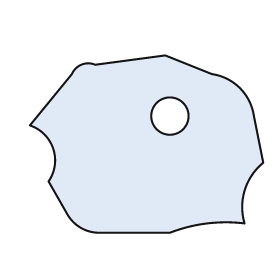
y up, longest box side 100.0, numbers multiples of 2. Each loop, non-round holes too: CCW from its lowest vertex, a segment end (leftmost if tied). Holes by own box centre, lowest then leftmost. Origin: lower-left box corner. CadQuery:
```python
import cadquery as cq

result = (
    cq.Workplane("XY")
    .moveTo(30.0, 0.0)
    .lineTo(60.0, 0.0)
    .threePointArc((76.0, 4.0), (92.0, 4.0))
    .threePointArc((92.0, 18.0), (100.0, 30.0))
    .lineTo(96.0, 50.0)
    .threePointArc((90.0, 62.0), (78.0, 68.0))
    .lineTo(58.0, 76.0)
    .lineTo(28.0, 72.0)
    .threePointArc((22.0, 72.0), (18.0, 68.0))
    .lineTo(0.0, 46.0)
    .threePointArc((10.0, 36.0), (8.0, 22.0))
    .lineTo(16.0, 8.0)
    .threePointArc((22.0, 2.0), (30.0, 0.0))
    .close()
    .moveTo(60.0, 50.0)
    .circle(8.0)
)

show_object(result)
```